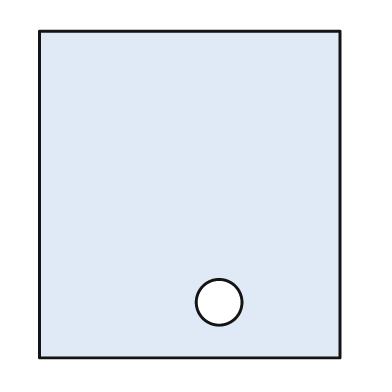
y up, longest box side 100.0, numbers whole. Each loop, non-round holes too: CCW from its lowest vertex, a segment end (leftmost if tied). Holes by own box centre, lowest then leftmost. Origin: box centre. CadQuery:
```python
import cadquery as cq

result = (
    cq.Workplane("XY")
    .moveTo(-46.0, -50.0)
    .lineTo(46.0, -50.0)
    .lineTo(46.0, 50.0)
    .lineTo(-46.0, 50.0)
    .close()
    .moveTo(9.0, -33.0)
    .circle(7.0)
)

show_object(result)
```